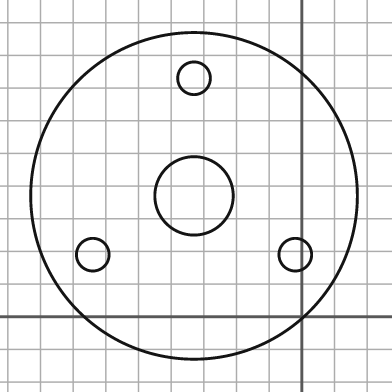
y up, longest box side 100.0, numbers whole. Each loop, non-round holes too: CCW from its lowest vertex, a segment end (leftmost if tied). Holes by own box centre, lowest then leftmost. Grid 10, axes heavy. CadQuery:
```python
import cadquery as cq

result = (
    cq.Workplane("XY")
    .moveTo(-33.0, 37.0)
    .circle(50.0)
    .moveTo(-64.0, 19.0)
    .circle(5.0)
    .moveTo(-2.0, 19.0)
    .circle(5.0)
    .moveTo(-33.0, 37.0)
    .circle(12.0)
    .moveTo(-33.0, 73.0)
    .circle(5.0)
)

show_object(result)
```